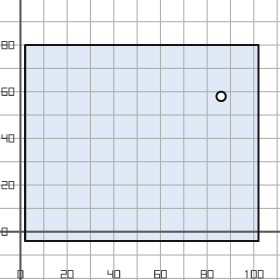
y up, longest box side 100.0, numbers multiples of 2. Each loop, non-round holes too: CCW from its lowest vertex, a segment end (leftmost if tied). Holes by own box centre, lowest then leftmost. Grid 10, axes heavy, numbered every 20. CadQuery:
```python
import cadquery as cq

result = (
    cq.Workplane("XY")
    .moveTo(2.0, -4.0)
    .lineTo(102.0, -4.0)
    .lineTo(102.0, 80.0)
    .lineTo(2.0, 80.0)
    .close()
    .moveTo(86.0, 58.0)
    .circle(2.0)
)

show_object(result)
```